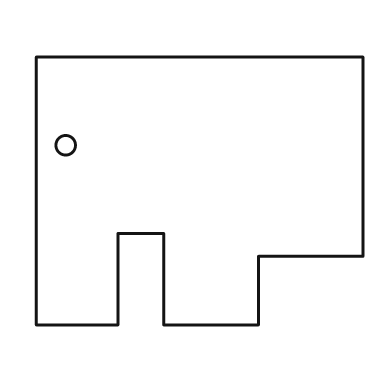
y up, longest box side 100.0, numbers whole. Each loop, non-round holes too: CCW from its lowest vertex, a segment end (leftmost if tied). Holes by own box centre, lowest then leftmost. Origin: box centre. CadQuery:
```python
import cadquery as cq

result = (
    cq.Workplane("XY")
    .moveTo(-50.0, -41.0)
    .lineTo(-25.0, -41.0)
    .lineTo(-25.0, -13.0)
    .lineTo(-11.0, -13.0)
    .lineTo(-11.0, -41.0)
    .lineTo(18.0, -41.0)
    .lineTo(18.0, -20.0)
    .lineTo(50.0, -20.0)
    .lineTo(50.0, 41.0)
    .lineTo(-50.0, 41.0)
    .close()
    .moveTo(-41.0, 14.0)
    .circle(3.0)
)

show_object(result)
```